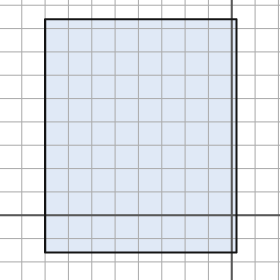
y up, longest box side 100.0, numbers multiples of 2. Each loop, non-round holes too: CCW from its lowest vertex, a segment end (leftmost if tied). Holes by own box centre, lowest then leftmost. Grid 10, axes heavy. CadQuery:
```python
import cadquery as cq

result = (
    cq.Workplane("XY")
    .moveTo(-80.0, -16.0)
    .lineTo(2.0, -16.0)
    .lineTo(2.0, 84.0)
    .lineTo(-80.0, 84.0)
    .close()
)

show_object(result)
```